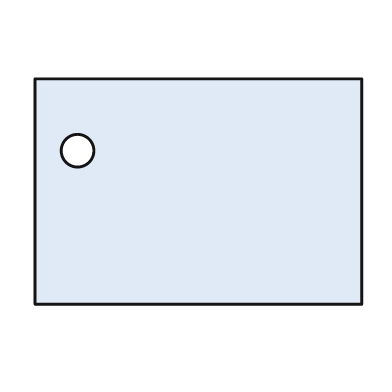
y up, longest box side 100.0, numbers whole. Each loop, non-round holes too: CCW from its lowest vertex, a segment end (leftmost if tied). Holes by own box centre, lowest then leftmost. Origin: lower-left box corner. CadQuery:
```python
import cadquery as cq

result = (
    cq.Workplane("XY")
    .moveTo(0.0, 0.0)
    .lineTo(100.0, 0.0)
    .lineTo(100.0, 69.0)
    .lineTo(0.0, 69.0)
    .close()
    .moveTo(13.0, 47.0)
    .circle(5.0)
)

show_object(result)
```